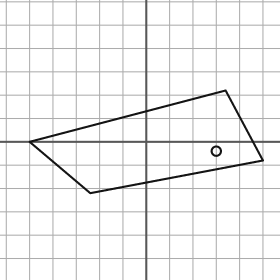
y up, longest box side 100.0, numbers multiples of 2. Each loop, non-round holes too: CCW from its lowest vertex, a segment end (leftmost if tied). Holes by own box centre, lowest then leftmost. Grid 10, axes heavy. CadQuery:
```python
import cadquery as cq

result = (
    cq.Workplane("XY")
    .moveTo(-24.0, -22.0)
    .lineTo(50.0, -8.0)
    .lineTo(34.0, 22.0)
    .lineTo(-50.0, 0.0)
    .close()
    .moveTo(30.0, -4.0)
    .circle(2.0)
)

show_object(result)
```